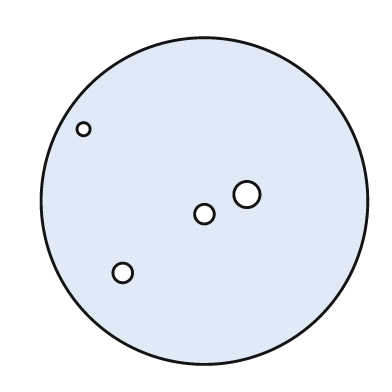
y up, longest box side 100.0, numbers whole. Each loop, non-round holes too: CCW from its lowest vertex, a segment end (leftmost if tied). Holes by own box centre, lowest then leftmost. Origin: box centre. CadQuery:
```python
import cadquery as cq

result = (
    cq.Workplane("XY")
    .moveTo(0.0, 0.0)
    .circle(50.0)
    .moveTo(-25.0, -22.0)
    .circle(3.0)
    .moveTo(0.0, -4.0)
    .circle(3.0)
    .moveTo(13.0, 2.0)
    .circle(4.0)
    .moveTo(-37.0, 22.0)
    .circle(2.0)
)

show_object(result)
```